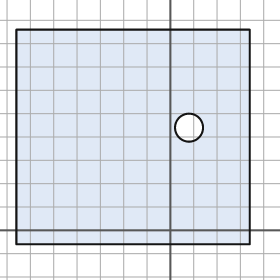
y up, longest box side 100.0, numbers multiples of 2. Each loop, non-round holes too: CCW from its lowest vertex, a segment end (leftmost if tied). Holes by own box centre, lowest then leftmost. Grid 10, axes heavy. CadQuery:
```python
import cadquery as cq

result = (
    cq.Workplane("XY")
    .moveTo(-66.0, -6.0)
    .lineTo(34.0, -6.0)
    .lineTo(34.0, 86.0)
    .lineTo(-66.0, 86.0)
    .close()
    .moveTo(8.0, 44.0)
    .circle(6.0)
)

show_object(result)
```